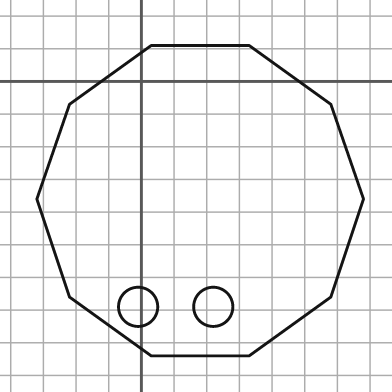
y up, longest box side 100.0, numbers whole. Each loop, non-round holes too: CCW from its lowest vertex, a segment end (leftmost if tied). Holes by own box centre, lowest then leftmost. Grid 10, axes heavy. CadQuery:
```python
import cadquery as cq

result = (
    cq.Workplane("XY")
    .moveTo(3.0, -84.0)
    .lineTo(33.0, -84.0)
    .lineTo(58.0, -66.0)
    .lineTo(68.0, -36.0)
    .lineTo(58.0, -7.0)
    .lineTo(33.0, 11.0)
    .lineTo(3.0, 11.0)
    .lineTo(-22.0, -7.0)
    .lineTo(-32.0, -36.0)
    .lineTo(-22.0, -66.0)
    .close()
    .moveTo(-1.0, -69.0)
    .circle(6.0)
    .moveTo(22.0, -69.0)
    .circle(6.0)
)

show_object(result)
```